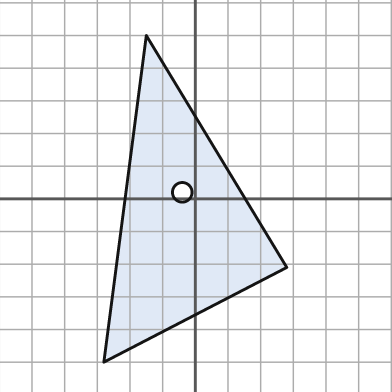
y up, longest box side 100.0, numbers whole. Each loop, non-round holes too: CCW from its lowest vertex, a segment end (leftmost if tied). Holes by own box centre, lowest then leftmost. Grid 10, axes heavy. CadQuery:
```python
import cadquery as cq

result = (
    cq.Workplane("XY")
    .moveTo(-28.0, -50.0)
    .lineTo(28.0, -21.0)
    .lineTo(-15.0, 50.0)
    .close()
    .moveTo(-4.0, 2.0)
    .circle(3.0)
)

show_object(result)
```